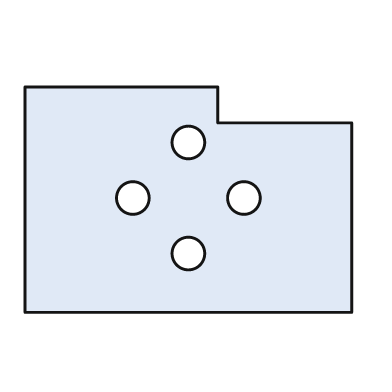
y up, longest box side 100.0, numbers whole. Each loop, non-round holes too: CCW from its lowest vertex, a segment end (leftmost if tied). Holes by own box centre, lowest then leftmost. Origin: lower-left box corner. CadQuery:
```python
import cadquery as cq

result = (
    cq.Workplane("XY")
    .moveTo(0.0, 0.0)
    .lineTo(100.0, 0.0)
    .lineTo(100.0, 58.0)
    .lineTo(59.0, 58.0)
    .lineTo(59.0, 69.0)
    .lineTo(0.0, 69.0)
    .close()
    .moveTo(50.0, 18.0)
    .circle(5.0)
    .moveTo(33.0, 35.0)
    .circle(5.0)
    .moveTo(67.0, 35.0)
    .circle(5.0)
    .moveTo(50.0, 52.0)
    .circle(5.0)
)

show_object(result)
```